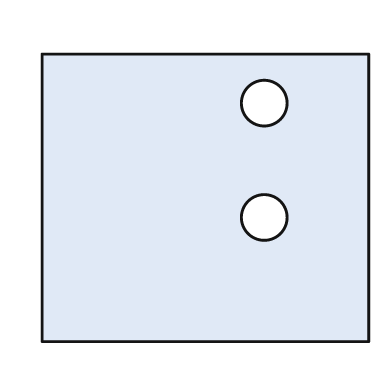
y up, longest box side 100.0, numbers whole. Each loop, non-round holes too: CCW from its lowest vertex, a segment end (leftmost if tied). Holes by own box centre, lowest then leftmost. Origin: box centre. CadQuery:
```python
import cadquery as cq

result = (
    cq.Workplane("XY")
    .moveTo(-50.0, -44.0)
    .lineTo(50.0, -44.0)
    .lineTo(50.0, 44.0)
    .lineTo(-50.0, 44.0)
    .close()
    .moveTo(18.0, -6.0)
    .circle(7.0)
    .moveTo(18.0, 29.0)
    .circle(7.0)
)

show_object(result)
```